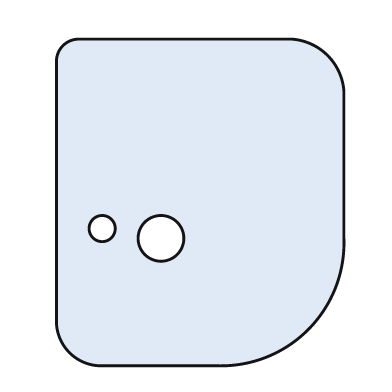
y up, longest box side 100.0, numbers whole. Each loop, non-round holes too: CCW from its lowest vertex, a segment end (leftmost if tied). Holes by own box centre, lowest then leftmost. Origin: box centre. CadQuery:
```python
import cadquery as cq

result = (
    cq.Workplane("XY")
    .moveTo(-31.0, -50.0)
    .lineTo(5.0, -50.0)
    .threePointArc((33.0, -39.0), (44.0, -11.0))
    .lineTo(44.0, 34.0)
    .threePointArc((39.0, 45.0), (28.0, 50.0))
    .lineTo(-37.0, 50.0)
    .threePointArc((-42.0, 48.0), (-44.0, 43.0))
    .lineTo(-44.0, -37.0)
    .threePointArc((-40.0, -46.0), (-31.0, -50.0))
    .close()
    .moveTo(-12.0, -11.0)
    .circle(7.0)
    .moveTo(-30.0, -8.0)
    .circle(4.0)
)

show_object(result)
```